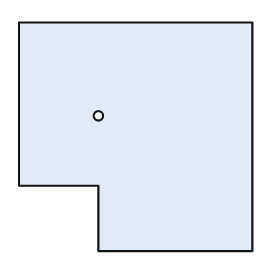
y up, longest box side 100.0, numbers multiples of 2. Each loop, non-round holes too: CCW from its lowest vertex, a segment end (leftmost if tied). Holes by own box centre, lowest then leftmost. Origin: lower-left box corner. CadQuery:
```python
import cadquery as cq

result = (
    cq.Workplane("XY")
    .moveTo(34.0, 0.0)
    .lineTo(100.0, 0.0)
    .lineTo(100.0, 98.0)
    .lineTo(0.0, 98.0)
    .lineTo(0.0, 28.0)
    .lineTo(34.0, 28.0)
    .close()
    .moveTo(34.0, 58.0)
    .circle(2.0)
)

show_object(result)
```